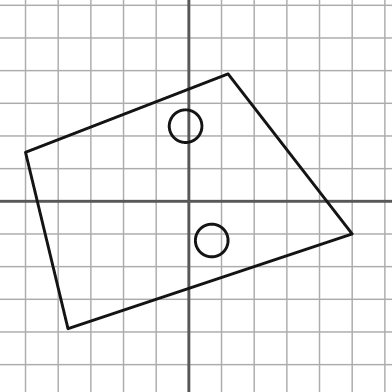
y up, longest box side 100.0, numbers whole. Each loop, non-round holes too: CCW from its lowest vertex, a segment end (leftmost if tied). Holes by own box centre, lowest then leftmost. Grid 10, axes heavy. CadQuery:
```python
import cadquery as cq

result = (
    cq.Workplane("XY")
    .moveTo(-37.0, -39.0)
    .lineTo(50.0, -10.0)
    .lineTo(12.0, 39.0)
    .lineTo(-50.0, 15.0)
    .close()
    .moveTo(7.0, -12.0)
    .circle(5.0)
    .moveTo(-1.0, 23.0)
    .circle(5.0)
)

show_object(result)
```